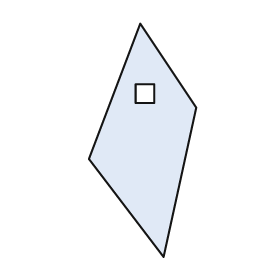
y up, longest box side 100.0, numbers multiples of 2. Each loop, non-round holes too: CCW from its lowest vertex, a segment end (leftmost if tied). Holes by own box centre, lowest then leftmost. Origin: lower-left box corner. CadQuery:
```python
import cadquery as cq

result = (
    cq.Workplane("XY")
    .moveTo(32.0, 0.0)
    .lineTo(46.0, 64.0)
    .lineTo(22.0, 100.0)
    .lineTo(0.0, 42.0)
    .close()
    .moveTo(20.0, 66.0)
    .lineTo(28.0, 66.0)
    .lineTo(28.0, 74.0)
    .lineTo(20.0, 74.0)
    .close()
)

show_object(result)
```